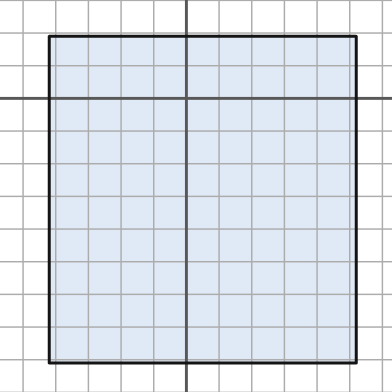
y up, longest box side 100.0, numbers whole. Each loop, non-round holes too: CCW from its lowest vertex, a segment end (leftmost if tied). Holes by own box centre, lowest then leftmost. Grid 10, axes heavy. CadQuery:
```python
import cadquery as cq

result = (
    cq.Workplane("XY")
    .moveTo(-42.0, -81.0)
    .lineTo(52.0, -81.0)
    .lineTo(52.0, 19.0)
    .lineTo(-42.0, 19.0)
    .close()
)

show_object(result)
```